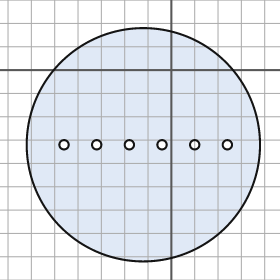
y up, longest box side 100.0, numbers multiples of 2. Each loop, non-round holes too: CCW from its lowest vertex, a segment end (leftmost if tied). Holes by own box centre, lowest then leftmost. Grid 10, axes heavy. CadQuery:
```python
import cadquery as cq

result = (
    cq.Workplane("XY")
    .moveTo(-12.0, -32.0)
    .circle(50.0)
    .moveTo(-46.0, -32.0)
    .circle(2.0)
    .moveTo(-32.0, -32.0)
    .circle(2.0)
    .moveTo(-18.0, -32.0)
    .circle(2.0)
    .moveTo(-4.0, -32.0)
    .circle(2.0)
    .moveTo(10.0, -32.0)
    .circle(2.0)
    .moveTo(24.0, -32.0)
    .circle(2.0)
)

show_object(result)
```